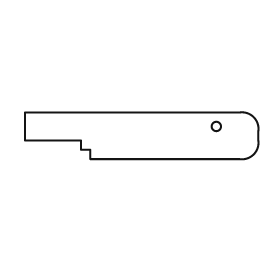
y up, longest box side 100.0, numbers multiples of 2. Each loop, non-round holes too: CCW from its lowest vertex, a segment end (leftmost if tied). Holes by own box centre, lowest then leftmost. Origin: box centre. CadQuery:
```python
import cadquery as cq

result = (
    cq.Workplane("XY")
    .moveTo(-22.0, -10.0)
    .lineTo(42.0, -10.0)
    .threePointArc((48.0, -8.0), (50.0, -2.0))
    .lineTo(50.0, 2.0)
    .threePointArc((48.0, 8.0), (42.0, 10.0))
    .lineTo(-50.0, 10.0)
    .lineTo(-50.0, -2.0)
    .lineTo(-26.0, -2.0)
    .lineTo(-26.0, -6.0)
    .lineTo(-22.0, -6.0)
    .close()
    .moveTo(32.0, 4.0)
    .circle(2.0)
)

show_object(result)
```